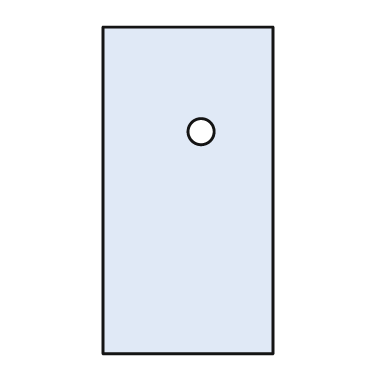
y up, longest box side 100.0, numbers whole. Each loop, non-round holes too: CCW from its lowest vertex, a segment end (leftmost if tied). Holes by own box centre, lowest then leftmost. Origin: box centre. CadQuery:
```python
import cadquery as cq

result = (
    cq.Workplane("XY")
    .moveTo(-26.0, -50.0)
    .lineTo(26.0, -50.0)
    .lineTo(26.0, 50.0)
    .lineTo(-26.0, 50.0)
    .close()
    .moveTo(4.0, 18.0)
    .circle(4.0)
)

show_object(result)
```